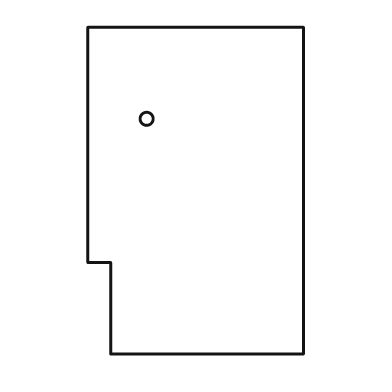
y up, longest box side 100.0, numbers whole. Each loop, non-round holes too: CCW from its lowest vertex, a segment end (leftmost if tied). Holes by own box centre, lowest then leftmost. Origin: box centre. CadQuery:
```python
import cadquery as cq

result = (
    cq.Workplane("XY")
    .moveTo(-26.0, -50.0)
    .lineTo(33.0, -50.0)
    .lineTo(33.0, 50.0)
    .lineTo(-33.0, 50.0)
    .lineTo(-33.0, -22.0)
    .lineTo(-26.0, -22.0)
    .close()
    .moveTo(-15.0, 22.0)
    .circle(2.0)
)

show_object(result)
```